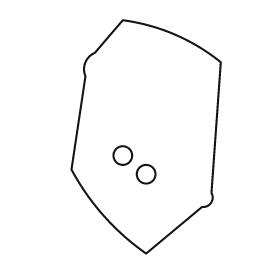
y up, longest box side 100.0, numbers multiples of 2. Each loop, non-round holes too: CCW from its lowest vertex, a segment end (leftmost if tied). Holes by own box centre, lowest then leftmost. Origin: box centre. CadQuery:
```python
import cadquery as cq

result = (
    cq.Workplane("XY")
    .moveTo(0.0, -50.0)
    .lineTo(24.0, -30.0)
    .threePointArc((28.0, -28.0), (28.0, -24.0))
    .lineTo(32.0, 32.0)
    .threePointArc((12.0, 44.0), (-10.0, 50.0))
    .lineTo(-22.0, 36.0)
    .threePointArc((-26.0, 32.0), (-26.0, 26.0))
    .lineTo(-32.0, -14.0)
    .threePointArc((-18.0, -34.0), (0.0, -50.0))
    .close()
    .moveTo(0.0, -16.0)
    .circle(4.0)
    .moveTo(-10.0, -8.0)
    .circle(4.0)
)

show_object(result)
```